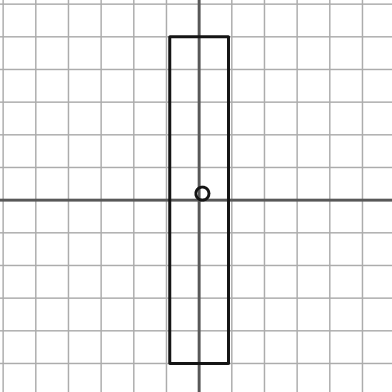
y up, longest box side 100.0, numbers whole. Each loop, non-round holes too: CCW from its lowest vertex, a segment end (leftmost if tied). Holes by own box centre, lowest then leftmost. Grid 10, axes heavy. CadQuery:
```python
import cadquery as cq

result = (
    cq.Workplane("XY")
    .moveTo(-9.0, -50.0)
    .lineTo(9.0, -50.0)
    .lineTo(9.0, 50.0)
    .lineTo(-9.0, 50.0)
    .close()
    .moveTo(1.0, 2.0)
    .circle(2.0)
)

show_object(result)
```